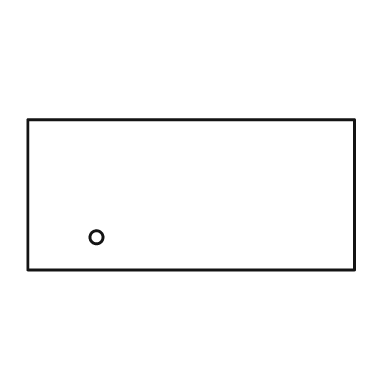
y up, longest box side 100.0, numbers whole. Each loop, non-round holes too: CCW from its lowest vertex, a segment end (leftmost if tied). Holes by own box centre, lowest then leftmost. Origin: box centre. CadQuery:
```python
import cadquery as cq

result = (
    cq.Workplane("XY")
    .moveTo(-50.0, -23.0)
    .lineTo(50.0, -23.0)
    .lineTo(50.0, 23.0)
    .lineTo(-50.0, 23.0)
    .close()
    .moveTo(-29.0, -13.0)
    .circle(2.0)
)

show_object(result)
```